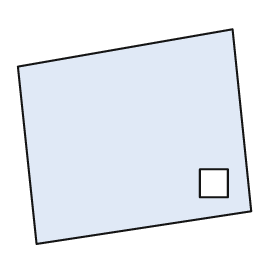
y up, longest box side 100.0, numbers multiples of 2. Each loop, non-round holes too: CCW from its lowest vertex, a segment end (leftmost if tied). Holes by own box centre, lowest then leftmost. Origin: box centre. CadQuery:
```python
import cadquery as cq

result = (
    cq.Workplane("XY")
    .moveTo(-42.0, -46.0)
    .lineTo(50.0, -32.0)
    .lineTo(42.0, 46.0)
    .lineTo(-50.0, 30.0)
    .close()
    .moveTo(28.0, -26.0)
    .lineTo(40.0, -26.0)
    .lineTo(40.0, -14.0)
    .lineTo(28.0, -14.0)
    .close()
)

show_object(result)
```